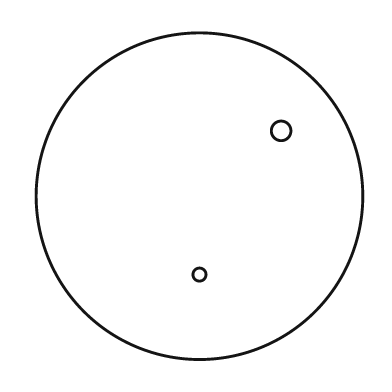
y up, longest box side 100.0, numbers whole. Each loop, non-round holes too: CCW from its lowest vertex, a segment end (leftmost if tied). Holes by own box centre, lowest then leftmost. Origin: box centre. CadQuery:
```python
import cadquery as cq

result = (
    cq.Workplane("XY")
    .moveTo(0.0, 0.0)
    .circle(50.0)
    .moveTo(0.0, -24.0)
    .circle(2.0)
    .moveTo(25.0, 20.0)
    .circle(3.0)
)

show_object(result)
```